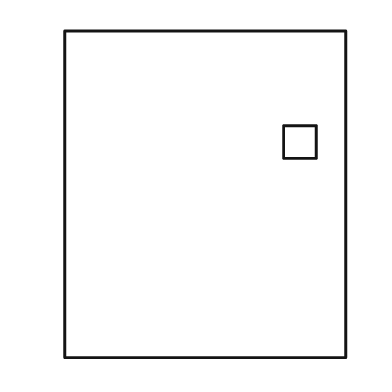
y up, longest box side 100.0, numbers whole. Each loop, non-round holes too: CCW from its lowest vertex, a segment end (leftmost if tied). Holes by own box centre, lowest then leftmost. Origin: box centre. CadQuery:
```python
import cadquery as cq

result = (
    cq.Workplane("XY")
    .moveTo(-43.0, -50.0)
    .lineTo(43.0, -50.0)
    .lineTo(43.0, 50.0)
    .lineTo(-43.0, 50.0)
    .close()
    .moveTo(24.0, 11.0)
    .lineTo(34.0, 11.0)
    .lineTo(34.0, 21.0)
    .lineTo(24.0, 21.0)
    .close()
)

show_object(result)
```